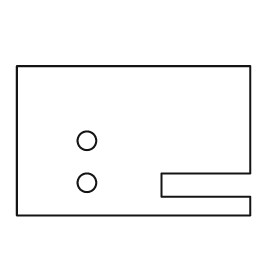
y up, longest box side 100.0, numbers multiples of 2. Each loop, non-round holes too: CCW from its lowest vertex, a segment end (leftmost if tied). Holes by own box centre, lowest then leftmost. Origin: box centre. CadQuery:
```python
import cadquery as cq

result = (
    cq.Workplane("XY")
    .moveTo(-50.0, -32.0)
    .lineTo(50.0, -32.0)
    .lineTo(50.0, -24.0)
    .lineTo(12.0, -24.0)
    .lineTo(12.0, -14.0)
    .lineTo(50.0, -14.0)
    .lineTo(50.0, 32.0)
    .lineTo(-50.0, 32.0)
    .close()
    .moveTo(-20.0, -18.0)
    .circle(4.0)
    .moveTo(-20.0, 0.0)
    .circle(4.0)
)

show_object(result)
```